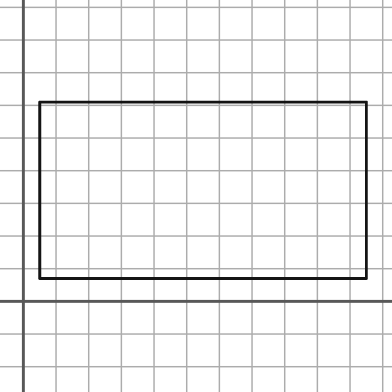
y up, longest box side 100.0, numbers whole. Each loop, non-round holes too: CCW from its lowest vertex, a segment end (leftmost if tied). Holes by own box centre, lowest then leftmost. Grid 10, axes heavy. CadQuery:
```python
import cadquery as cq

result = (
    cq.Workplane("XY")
    .moveTo(5.0, 7.0)
    .lineTo(105.0, 7.0)
    .lineTo(105.0, 61.0)
    .lineTo(5.0, 61.0)
    .close()
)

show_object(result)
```